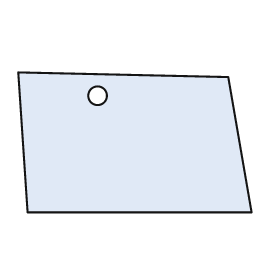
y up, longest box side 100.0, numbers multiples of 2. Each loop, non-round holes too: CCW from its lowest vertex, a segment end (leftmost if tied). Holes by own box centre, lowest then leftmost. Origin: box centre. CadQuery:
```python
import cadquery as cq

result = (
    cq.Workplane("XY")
    .moveTo(-46.0, -30.0)
    .lineTo(50.0, -30.0)
    .lineTo(40.0, 28.0)
    .lineTo(-50.0, 30.0)
    .close()
    .moveTo(-16.0, 20.0)
    .circle(4.0)
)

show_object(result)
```